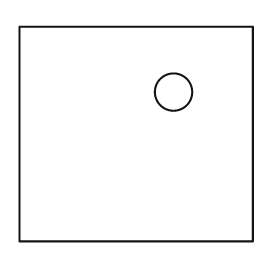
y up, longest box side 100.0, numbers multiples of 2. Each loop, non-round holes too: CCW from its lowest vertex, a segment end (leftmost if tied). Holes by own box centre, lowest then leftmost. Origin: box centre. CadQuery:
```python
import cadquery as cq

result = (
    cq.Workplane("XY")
    .moveTo(-50.0, -46.0)
    .lineTo(50.0, -46.0)
    .lineTo(50.0, 46.0)
    .lineTo(-50.0, 46.0)
    .close()
    .moveTo(16.0, 18.0)
    .circle(8.0)
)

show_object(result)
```